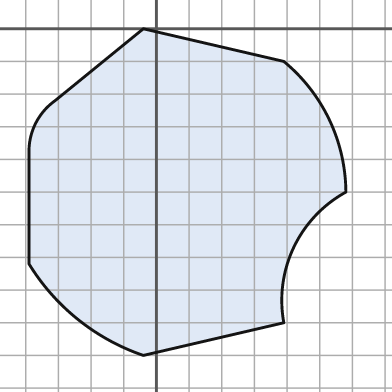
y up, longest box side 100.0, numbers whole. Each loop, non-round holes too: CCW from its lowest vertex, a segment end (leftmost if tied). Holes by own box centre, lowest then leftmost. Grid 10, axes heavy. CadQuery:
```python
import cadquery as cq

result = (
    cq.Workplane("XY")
    .moveTo(-4.0, -100.0)
    .lineTo(39.0, -90.0)
    .threePointArc((42.0, -67.0), (58.0, -50.0))
    .threePointArc((53.0, -28.0), (39.0, -10.0))
    .lineTo(-4.0, 0.0)
    .lineTo(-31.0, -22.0)
    .threePointArc((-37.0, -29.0), (-39.0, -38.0))
    .lineTo(-39.0, -72.0)
    .threePointArc((-24.0, -89.0), (-4.0, -100.0))
    .close()
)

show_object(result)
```